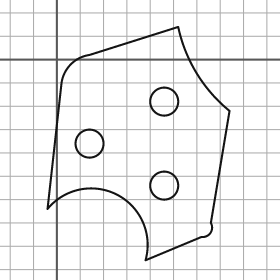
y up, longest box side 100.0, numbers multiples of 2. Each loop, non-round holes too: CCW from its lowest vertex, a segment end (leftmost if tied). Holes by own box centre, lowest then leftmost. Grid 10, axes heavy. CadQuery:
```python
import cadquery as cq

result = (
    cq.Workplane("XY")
    .moveTo(38.0, -86.0)
    .lineTo(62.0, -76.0)
    .threePointArc((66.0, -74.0), (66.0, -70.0))
    .lineTo(74.0, -22.0)
    .threePointArc((60.0, -6.0), (52.0, 14.0))
    .lineTo(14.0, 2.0)
    .threePointArc((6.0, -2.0), (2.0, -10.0))
    .lineTo(-4.0, -64.0)
    .threePointArc((26.0, -58.0), (38.0, -86.0))
    .close()
    .moveTo(46.0, -54.0)
    .circle(6.0)
    .moveTo(14.0, -36.0)
    .circle(6.0)
    .moveTo(46.0, -18.0)
    .circle(6.0)
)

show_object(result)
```